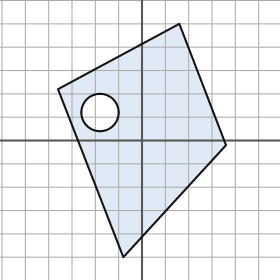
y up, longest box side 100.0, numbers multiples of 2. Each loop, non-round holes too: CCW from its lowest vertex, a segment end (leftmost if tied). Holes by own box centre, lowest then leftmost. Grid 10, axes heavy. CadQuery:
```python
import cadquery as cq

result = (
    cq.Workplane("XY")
    .moveTo(-8.0, -50.0)
    .lineTo(36.0, -2.0)
    .lineTo(16.0, 50.0)
    .lineTo(-36.0, 22.0)
    .close()
    .moveTo(-18.0, 12.0)
    .circle(8.0)
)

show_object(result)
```